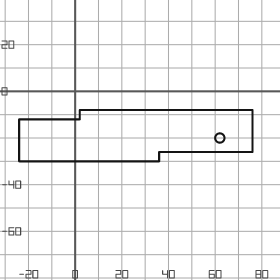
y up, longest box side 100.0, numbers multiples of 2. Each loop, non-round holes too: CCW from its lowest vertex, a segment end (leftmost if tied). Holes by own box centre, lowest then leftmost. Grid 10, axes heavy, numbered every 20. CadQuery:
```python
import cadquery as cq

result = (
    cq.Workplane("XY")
    .moveTo(-24.0, -30.0)
    .lineTo(36.0, -30.0)
    .lineTo(36.0, -26.0)
    .lineTo(76.0, -26.0)
    .lineTo(76.0, -8.0)
    .lineTo(2.0, -8.0)
    .lineTo(2.0, -12.0)
    .lineTo(-24.0, -12.0)
    .close()
    .moveTo(62.0, -20.0)
    .circle(2.0)
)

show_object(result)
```